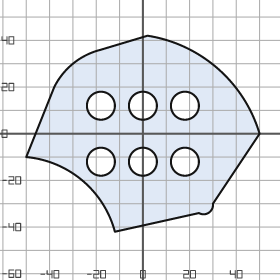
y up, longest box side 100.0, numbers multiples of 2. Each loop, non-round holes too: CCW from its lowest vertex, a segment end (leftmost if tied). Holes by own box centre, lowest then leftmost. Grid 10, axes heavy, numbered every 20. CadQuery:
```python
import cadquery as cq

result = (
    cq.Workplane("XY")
    .moveTo(-12.0, -42.0)
    .lineTo(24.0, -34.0)
    .threePointArc((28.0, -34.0), (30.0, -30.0))
    .lineTo(50.0, 0.0)
    .threePointArc((32.0, 28.0), (2.0, 42.0))
    .lineTo(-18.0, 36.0)
    .threePointArc((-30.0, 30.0), (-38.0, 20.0))
    .lineTo(-50.0, -10.0)
    .threePointArc((-26.0, -20.0), (-12.0, -42.0))
    .close()
    .moveTo(-18.0, -12.0)
    .circle(6.0)
    .moveTo(0.0, -12.0)
    .circle(6.0)
    .moveTo(18.0, -12.0)
    .circle(6.0)
    .moveTo(-18.0, 12.0)
    .circle(6.0)
    .moveTo(0.0, 12.0)
    .circle(6.0)
    .moveTo(18.0, 12.0)
    .circle(6.0)
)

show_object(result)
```